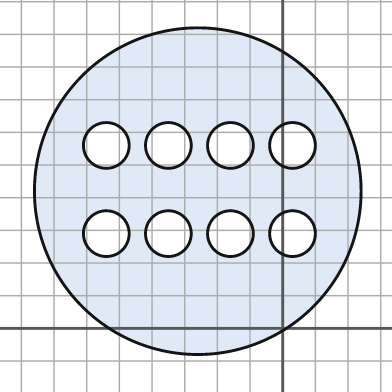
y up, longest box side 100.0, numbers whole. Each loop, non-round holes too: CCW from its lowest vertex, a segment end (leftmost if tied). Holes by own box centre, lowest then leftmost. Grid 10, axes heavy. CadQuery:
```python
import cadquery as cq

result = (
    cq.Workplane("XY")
    .moveTo(-26.0, 42.0)
    .circle(50.0)
    .moveTo(-54.0, 29.0)
    .circle(7.0)
    .moveTo(-35.0, 29.0)
    .circle(7.0)
    .moveTo(-16.0, 29.0)
    .circle(7.0)
    .moveTo(3.0, 29.0)
    .circle(7.0)
    .moveTo(-54.0, 56.0)
    .circle(7.0)
    .moveTo(-35.0, 56.0)
    .circle(7.0)
    .moveTo(-16.0, 56.0)
    .circle(7.0)
    .moveTo(3.0, 56.0)
    .circle(7.0)
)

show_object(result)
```